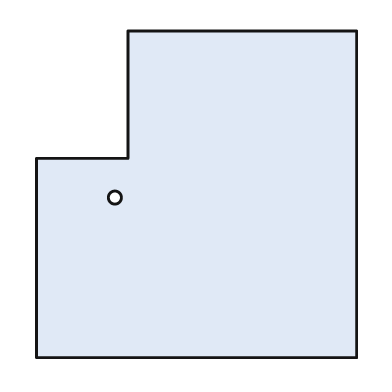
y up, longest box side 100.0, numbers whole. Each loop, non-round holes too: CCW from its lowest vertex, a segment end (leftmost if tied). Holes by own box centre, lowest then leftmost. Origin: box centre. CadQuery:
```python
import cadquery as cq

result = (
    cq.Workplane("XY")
    .moveTo(-49.0, -50.0)
    .lineTo(49.0, -50.0)
    .lineTo(49.0, 50.0)
    .lineTo(-21.0, 50.0)
    .lineTo(-21.0, 11.0)
    .lineTo(-49.0, 11.0)
    .close()
    .moveTo(-25.0, -1.0)
    .circle(2.0)
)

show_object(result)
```